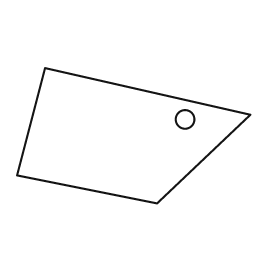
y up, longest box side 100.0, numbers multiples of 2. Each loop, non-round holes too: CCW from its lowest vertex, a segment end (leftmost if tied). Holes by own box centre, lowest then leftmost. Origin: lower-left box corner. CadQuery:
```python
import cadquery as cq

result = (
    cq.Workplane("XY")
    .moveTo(60.0, 0.0)
    .lineTo(100.0, 38.0)
    .lineTo(12.0, 58.0)
    .lineTo(0.0, 12.0)
    .close()
    .moveTo(72.0, 36.0)
    .circle(4.0)
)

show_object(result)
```